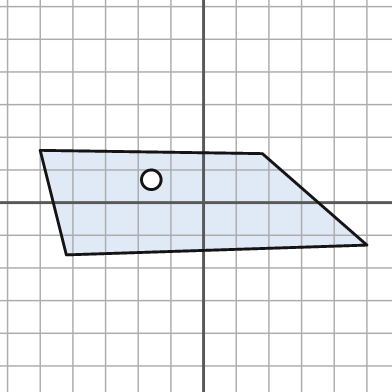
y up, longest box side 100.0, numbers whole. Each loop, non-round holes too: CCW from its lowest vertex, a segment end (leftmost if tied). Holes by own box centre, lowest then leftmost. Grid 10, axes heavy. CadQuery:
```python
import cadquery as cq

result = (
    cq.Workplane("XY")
    .moveTo(-42.0, -16.0)
    .lineTo(50.0, -13.0)
    .lineTo(18.0, 15.0)
    .lineTo(-50.0, 16.0)
    .close()
    .moveTo(-16.0, 7.0)
    .circle(3.0)
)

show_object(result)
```